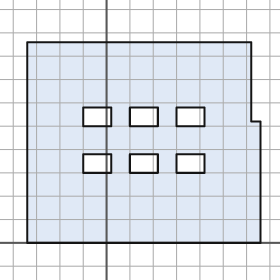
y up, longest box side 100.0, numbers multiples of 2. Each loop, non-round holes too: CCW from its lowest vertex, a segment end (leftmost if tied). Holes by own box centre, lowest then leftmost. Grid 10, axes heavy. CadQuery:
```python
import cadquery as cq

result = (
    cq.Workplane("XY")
    .moveTo(-34.0, 0.0)
    .lineTo(66.0, 0.0)
    .lineTo(66.0, 52.0)
    .lineTo(62.0, 52.0)
    .lineTo(62.0, 86.0)
    .lineTo(-34.0, 86.0)
    .close()
    .moveTo(-10.0, 30.0)
    .lineTo(2.0, 30.0)
    .lineTo(2.0, 38.0)
    .lineTo(-10.0, 38.0)
    .close()
    .moveTo(10.0, 30.0)
    .lineTo(22.0, 30.0)
    .lineTo(22.0, 38.0)
    .lineTo(10.0, 38.0)
    .close()
    .moveTo(30.0, 30.0)
    .lineTo(42.0, 30.0)
    .lineTo(42.0, 38.0)
    .lineTo(30.0, 38.0)
    .close()
    .moveTo(-10.0, 50.0)
    .lineTo(2.0, 50.0)
    .lineTo(2.0, 58.0)
    .lineTo(-10.0, 58.0)
    .close()
    .moveTo(10.0, 50.0)
    .lineTo(22.0, 50.0)
    .lineTo(22.0, 58.0)
    .lineTo(10.0, 58.0)
    .close()
    .moveTo(30.0, 50.0)
    .lineTo(42.0, 50.0)
    .lineTo(42.0, 58.0)
    .lineTo(30.0, 58.0)
    .close()
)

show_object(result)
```